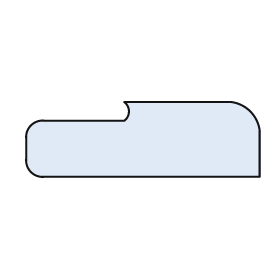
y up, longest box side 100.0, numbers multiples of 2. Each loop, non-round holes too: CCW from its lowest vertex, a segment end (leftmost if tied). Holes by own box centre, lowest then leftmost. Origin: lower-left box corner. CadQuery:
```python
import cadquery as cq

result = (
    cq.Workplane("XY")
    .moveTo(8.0, 0.0)
    .lineTo(100.0, 0.0)
    .lineTo(100.0, 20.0)
    .threePointArc((96.0, 28.0), (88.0, 32.0))
    .lineTo(42.0, 32.0)
    .threePointArc((44.0, 28.0), (42.0, 24.0))
    .lineTo(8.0, 24.0)
    .threePointArc((2.0, 22.0), (0.0, 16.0))
    .lineTo(0.0, 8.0)
    .threePointArc((2.0, 2.0), (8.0, 0.0))
    .close()
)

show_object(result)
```